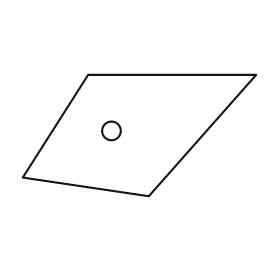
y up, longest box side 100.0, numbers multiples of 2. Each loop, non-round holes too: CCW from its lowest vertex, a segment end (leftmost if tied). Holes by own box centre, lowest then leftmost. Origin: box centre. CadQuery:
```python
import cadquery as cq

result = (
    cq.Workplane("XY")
    .moveTo(4.0, -26.0)
    .lineTo(50.0, 26.0)
    .lineTo(-22.0, 26.0)
    .lineTo(-50.0, -18.0)
    .close()
    .moveTo(-12.0, 2.0)
    .circle(4.0)
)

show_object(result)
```